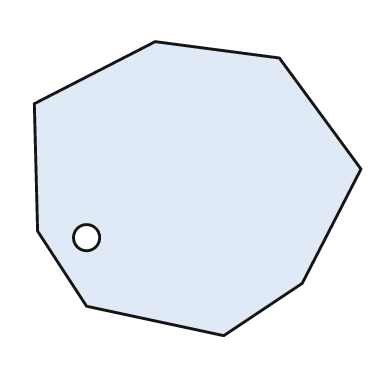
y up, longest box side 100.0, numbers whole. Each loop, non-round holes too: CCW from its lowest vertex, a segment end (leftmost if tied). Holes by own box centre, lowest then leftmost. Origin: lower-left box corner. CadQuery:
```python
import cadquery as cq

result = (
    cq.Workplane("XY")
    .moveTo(58.0, 0.0)
    .lineTo(82.0, 16.0)
    .lineTo(100.0, 51.0)
    .lineTo(75.0, 85.0)
    .lineTo(37.0, 90.0)
    .lineTo(0.0, 71.0)
    .lineTo(1.0, 32.0)
    .lineTo(16.0, 9.0)
    .close()
    .moveTo(16.0, 30.0)
    .circle(4.0)
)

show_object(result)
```